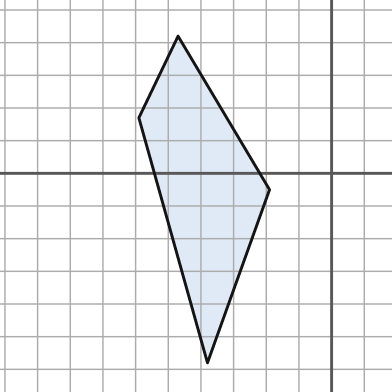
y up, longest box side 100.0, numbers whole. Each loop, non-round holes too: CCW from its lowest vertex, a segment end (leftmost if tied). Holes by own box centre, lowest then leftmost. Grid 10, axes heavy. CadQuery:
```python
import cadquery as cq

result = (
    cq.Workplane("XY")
    .moveTo(-38.0, -58.0)
    .lineTo(-19.0, -5.0)
    .lineTo(-47.0, 42.0)
    .lineTo(-59.0, 17.0)
    .close()
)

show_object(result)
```